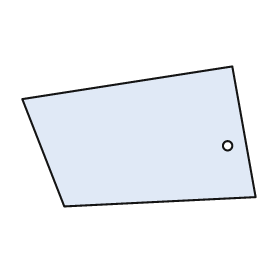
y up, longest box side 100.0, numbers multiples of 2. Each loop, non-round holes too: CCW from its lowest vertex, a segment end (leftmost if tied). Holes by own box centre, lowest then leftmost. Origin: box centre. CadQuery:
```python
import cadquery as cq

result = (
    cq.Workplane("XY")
    .moveTo(-32.0, -30.0)
    .lineTo(50.0, -26.0)
    .lineTo(40.0, 30.0)
    .lineTo(-50.0, 16.0)
    .close()
    .moveTo(38.0, -4.0)
    .circle(2.0)
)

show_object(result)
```